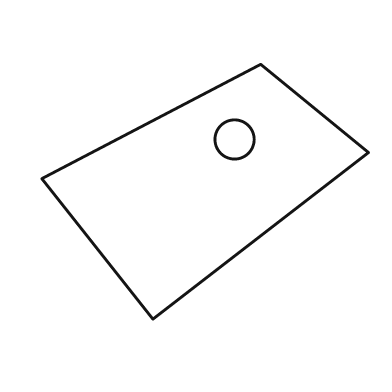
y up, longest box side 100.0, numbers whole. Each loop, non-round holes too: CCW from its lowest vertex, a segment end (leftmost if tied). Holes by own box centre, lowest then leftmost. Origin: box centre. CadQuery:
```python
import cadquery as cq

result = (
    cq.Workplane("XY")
    .moveTo(-16.0, -39.0)
    .lineTo(50.0, 12.0)
    .lineTo(17.0, 39.0)
    .lineTo(-50.0, 4.0)
    .close()
    .moveTo(9.0, 16.0)
    .circle(6.0)
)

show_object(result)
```